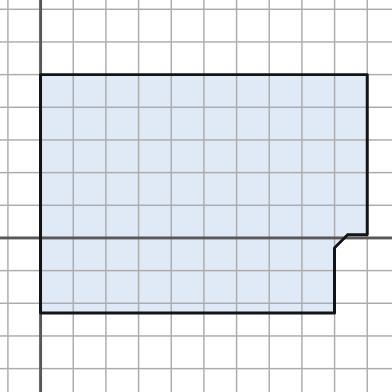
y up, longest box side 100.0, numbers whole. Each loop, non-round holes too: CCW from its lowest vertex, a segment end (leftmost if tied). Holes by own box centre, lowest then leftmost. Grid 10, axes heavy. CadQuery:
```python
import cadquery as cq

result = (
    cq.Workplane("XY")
    .moveTo(0.0, -23.0)
    .lineTo(90.0, -23.0)
    .lineTo(90.0, -3.0)
    .lineTo(94.0, 1.0)
    .lineTo(100.0, 1.0)
    .lineTo(100.0, 50.0)
    .lineTo(0.0, 50.0)
    .close()
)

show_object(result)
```